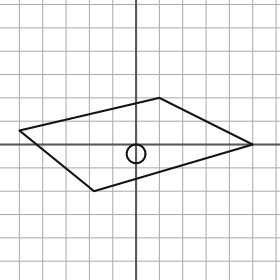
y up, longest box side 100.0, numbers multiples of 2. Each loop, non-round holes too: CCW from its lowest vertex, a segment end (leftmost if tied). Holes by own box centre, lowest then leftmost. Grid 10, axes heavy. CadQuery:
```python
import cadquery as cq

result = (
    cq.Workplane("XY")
    .moveTo(-18.0, -20.0)
    .lineTo(50.0, 0.0)
    .lineTo(10.0, 20.0)
    .lineTo(-50.0, 6.0)
    .close()
    .moveTo(0.0, -4.0)
    .circle(4.0)
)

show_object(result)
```